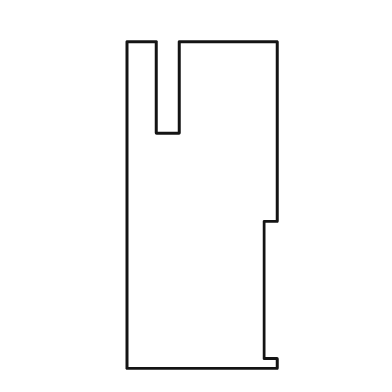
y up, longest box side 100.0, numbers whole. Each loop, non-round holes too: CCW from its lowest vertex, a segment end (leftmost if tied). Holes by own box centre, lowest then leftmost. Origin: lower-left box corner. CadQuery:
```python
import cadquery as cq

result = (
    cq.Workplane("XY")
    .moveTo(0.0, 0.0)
    .lineTo(46.0, 0.0)
    .lineTo(46.0, 3.0)
    .lineTo(42.0, 3.0)
    .lineTo(42.0, 45.0)
    .lineTo(46.0, 45.0)
    .lineTo(46.0, 100.0)
    .lineTo(16.0, 100.0)
    .lineTo(16.0, 72.0)
    .lineTo(9.0, 72.0)
    .lineTo(9.0, 100.0)
    .lineTo(0.0, 100.0)
    .close()
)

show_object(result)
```